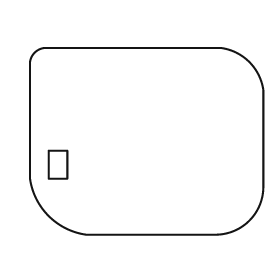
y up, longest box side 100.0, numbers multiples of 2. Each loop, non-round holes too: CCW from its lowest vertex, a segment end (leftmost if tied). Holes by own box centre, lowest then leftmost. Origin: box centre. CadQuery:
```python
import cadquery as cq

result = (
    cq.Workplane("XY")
    .moveTo(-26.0, -40.0)
    .lineTo(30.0, -40.0)
    .threePointArc((44.0, -34.0), (50.0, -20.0))
    .lineTo(50.0, 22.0)
    .threePointArc((44.0, 34.0), (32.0, 40.0))
    .lineTo(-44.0, 40.0)
    .threePointArc((-48.0, 38.0), (-50.0, 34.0))
    .lineTo(-50.0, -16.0)
    .threePointArc((-42.0, -32.0), (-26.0, -40.0))
    .close()
    .moveTo(-42.0, -16.0)
    .lineTo(-34.0, -16.0)
    .lineTo(-34.0, -4.0)
    .lineTo(-42.0, -4.0)
    .close()
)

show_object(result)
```